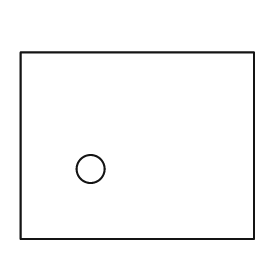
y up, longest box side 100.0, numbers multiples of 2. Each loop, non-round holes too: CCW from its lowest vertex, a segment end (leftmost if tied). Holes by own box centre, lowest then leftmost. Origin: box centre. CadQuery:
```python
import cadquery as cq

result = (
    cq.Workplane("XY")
    .moveTo(-50.0, -40.0)
    .lineTo(50.0, -40.0)
    .lineTo(50.0, 40.0)
    .lineTo(-50.0, 40.0)
    .close()
    .moveTo(-20.0, -10.0)
    .circle(6.0)
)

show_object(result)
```